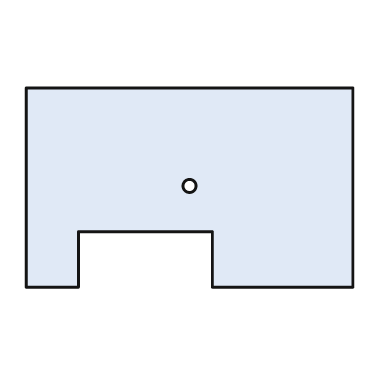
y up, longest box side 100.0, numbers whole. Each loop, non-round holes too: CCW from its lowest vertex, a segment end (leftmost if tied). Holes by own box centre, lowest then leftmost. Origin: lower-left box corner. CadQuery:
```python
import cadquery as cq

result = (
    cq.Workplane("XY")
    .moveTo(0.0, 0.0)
    .lineTo(16.0, 0.0)
    .lineTo(16.0, 17.0)
    .lineTo(57.0, 17.0)
    .lineTo(57.0, 0.0)
    .lineTo(100.0, 0.0)
    .lineTo(100.0, 61.0)
    .lineTo(0.0, 61.0)
    .close()
    .moveTo(50.0, 31.0)
    .circle(2.0)
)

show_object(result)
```